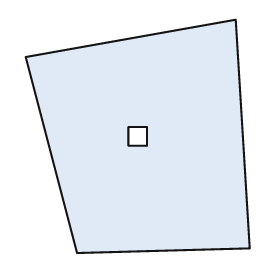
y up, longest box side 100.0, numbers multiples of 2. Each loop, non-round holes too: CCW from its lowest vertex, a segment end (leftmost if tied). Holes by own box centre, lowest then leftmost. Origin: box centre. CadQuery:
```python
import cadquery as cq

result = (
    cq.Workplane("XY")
    .moveTo(-26.0, -50.0)
    .lineTo(48.0, -48.0)
    .lineTo(42.0, 50.0)
    .lineTo(-48.0, 34.0)
    .close()
    .moveTo(-4.0, -4.0)
    .lineTo(4.0, -4.0)
    .lineTo(4.0, 4.0)
    .lineTo(-4.0, 4.0)
    .close()
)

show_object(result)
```